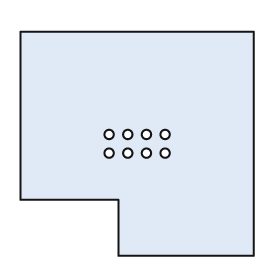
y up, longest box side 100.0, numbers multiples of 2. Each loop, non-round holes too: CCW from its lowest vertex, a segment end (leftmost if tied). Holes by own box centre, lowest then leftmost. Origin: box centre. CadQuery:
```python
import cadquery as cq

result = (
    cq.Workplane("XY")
    .moveTo(-8.0, -48.0)
    .lineTo(50.0, -48.0)
    .lineTo(50.0, 48.0)
    .lineTo(-50.0, 48.0)
    .lineTo(-50.0, -24.0)
    .lineTo(-8.0, -24.0)
    .close()
    .moveTo(-12.0, -4.0)
    .circle(2.0)
    .moveTo(-4.0, -4.0)
    .circle(2.0)
    .moveTo(4.0, -4.0)
    .circle(2.0)
    .moveTo(12.0, -4.0)
    .circle(2.0)
    .moveTo(-12.0, 4.0)
    .circle(2.0)
    .moveTo(-4.0, 4.0)
    .circle(2.0)
    .moveTo(4.0, 4.0)
    .circle(2.0)
    .moveTo(12.0, 4.0)
    .circle(2.0)
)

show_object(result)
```